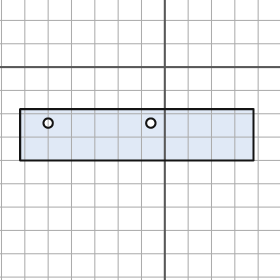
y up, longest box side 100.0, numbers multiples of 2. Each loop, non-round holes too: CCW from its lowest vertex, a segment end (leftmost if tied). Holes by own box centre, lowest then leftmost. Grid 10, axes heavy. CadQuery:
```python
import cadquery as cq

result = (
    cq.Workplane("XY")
    .moveTo(-62.0, -40.0)
    .lineTo(38.0, -40.0)
    .lineTo(38.0, -18.0)
    .lineTo(-62.0, -18.0)
    .close()
    .moveTo(-50.0, -24.0)
    .circle(2.0)
    .moveTo(-6.0, -24.0)
    .circle(2.0)
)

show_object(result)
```